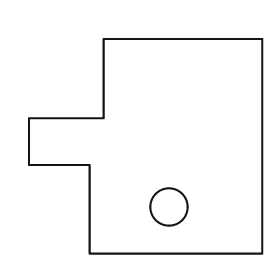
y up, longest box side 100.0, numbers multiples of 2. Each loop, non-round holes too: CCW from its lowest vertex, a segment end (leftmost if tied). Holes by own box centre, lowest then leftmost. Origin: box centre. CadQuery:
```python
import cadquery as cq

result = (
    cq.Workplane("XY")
    .moveTo(-24.0, -46.0)
    .lineTo(50.0, -46.0)
    .lineTo(50.0, 46.0)
    .lineTo(-18.0, 46.0)
    .lineTo(-18.0, 12.0)
    .lineTo(-50.0, 12.0)
    .lineTo(-50.0, -8.0)
    .lineTo(-24.0, -8.0)
    .close()
    .moveTo(10.0, -26.0)
    .circle(8.0)
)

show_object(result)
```